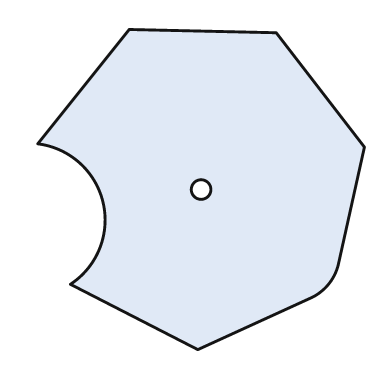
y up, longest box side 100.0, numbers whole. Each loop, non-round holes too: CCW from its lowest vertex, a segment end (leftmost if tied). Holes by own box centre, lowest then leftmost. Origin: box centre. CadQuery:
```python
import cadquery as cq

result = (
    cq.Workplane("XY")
    .moveTo(-1.0, -49.0)
    .lineTo(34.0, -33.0)
    .threePointArc((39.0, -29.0), (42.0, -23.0))
    .lineTo(50.0, 13.0)
    .lineTo(23.0, 48.0)
    .lineTo(-22.0, 49.0)
    .lineTo(-50.0, 14.0)
    .threePointArc((-30.0, -4.0), (-40.0, -29.0))
    .close()
    .moveTo(0.0, 0.0)
    .circle(3.0)
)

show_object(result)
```